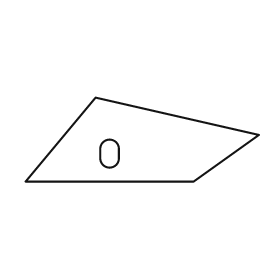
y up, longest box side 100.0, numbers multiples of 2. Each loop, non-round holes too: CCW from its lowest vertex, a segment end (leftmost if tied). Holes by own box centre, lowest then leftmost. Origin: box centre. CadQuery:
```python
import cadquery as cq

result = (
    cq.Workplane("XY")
    .moveTo(-50.0, -18.0)
    .lineTo(22.0, -18.0)
    .lineTo(50.0, 2.0)
    .lineTo(-20.0, 18.0)
    .close()
    .moveTo(-18.0, -8.0)
    .threePointArc((-14.0, -12.0), (-10.0, -8.0))
    .lineTo(-10.0, -4.0)
    .threePointArc((-14.0, 0.0), (-18.0, -4.0))
    .close()
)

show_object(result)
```